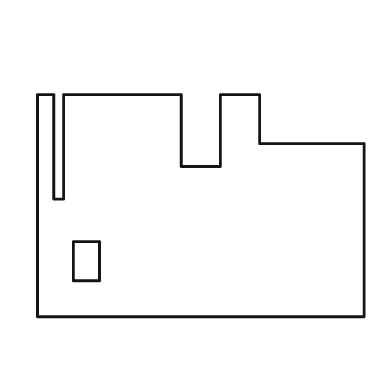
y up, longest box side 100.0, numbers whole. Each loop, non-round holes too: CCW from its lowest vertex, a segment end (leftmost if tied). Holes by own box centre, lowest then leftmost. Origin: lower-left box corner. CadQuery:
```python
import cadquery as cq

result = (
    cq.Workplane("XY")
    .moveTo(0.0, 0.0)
    .lineTo(100.0, 0.0)
    .lineTo(100.0, 53.0)
    .lineTo(68.0, 53.0)
    .lineTo(68.0, 68.0)
    .lineTo(56.0, 68.0)
    .lineTo(56.0, 46.0)
    .lineTo(44.0, 46.0)
    .lineTo(44.0, 68.0)
    .lineTo(8.0, 68.0)
    .lineTo(8.0, 36.0)
    .lineTo(5.0, 36.0)
    .lineTo(5.0, 68.0)
    .lineTo(0.0, 68.0)
    .close()
    .moveTo(11.0, 11.0)
    .lineTo(19.0, 11.0)
    .lineTo(19.0, 23.0)
    .lineTo(11.0, 23.0)
    .close()
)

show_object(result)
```